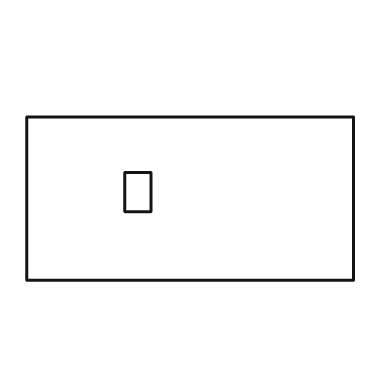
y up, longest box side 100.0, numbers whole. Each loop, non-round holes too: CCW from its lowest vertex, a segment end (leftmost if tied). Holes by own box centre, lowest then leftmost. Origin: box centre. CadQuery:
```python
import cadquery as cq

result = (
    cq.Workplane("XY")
    .moveTo(-50.0, -25.0)
    .lineTo(50.0, -25.0)
    .lineTo(50.0, 25.0)
    .lineTo(-50.0, 25.0)
    .close()
    .moveTo(-20.0, -4.0)
    .lineTo(-12.0, -4.0)
    .lineTo(-12.0, 8.0)
    .lineTo(-20.0, 8.0)
    .close()
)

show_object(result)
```